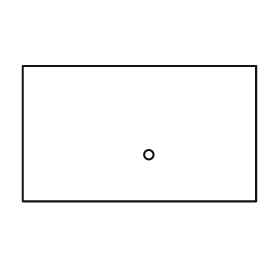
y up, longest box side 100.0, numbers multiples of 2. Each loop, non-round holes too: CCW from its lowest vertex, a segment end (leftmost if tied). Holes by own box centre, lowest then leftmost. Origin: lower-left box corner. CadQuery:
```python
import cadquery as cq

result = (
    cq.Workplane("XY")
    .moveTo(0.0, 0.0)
    .lineTo(100.0, 0.0)
    .lineTo(100.0, 58.0)
    .lineTo(0.0, 58.0)
    .close()
    .moveTo(54.0, 20.0)
    .circle(2.0)
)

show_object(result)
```